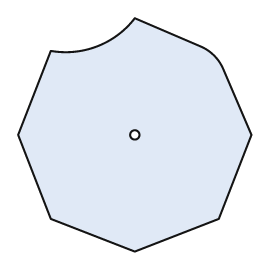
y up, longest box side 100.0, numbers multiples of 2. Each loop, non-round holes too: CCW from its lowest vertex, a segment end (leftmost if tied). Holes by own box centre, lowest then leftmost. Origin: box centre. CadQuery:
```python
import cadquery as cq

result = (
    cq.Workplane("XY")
    .moveTo(0.0, -50.0)
    .lineTo(36.0, -36.0)
    .lineTo(50.0, 0.0)
    .lineTo(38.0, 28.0)
    .threePointArc((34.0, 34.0), (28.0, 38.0))
    .lineTo(0.0, 50.0)
    .threePointArc((-16.0, 38.0), (-36.0, 36.0))
    .lineTo(-50.0, 0.0)
    .lineTo(-36.0, -36.0)
    .close()
    .moveTo(0.0, 0.0)
    .circle(2.0)
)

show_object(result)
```